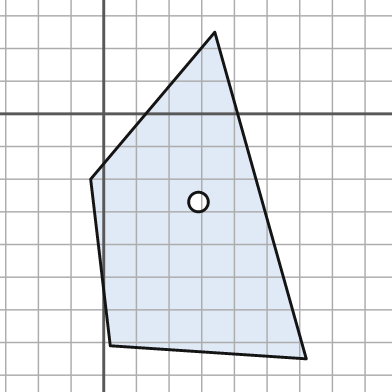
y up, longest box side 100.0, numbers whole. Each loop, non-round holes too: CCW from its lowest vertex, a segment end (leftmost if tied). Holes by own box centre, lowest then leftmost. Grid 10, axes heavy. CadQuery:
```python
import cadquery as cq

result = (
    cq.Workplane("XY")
    .moveTo(62.0, -75.0)
    .lineTo(34.0, 25.0)
    .lineTo(-4.0, -20.0)
    .lineTo(2.0, -71.0)
    .close()
    .moveTo(29.0, -27.0)
    .circle(3.0)
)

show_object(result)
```